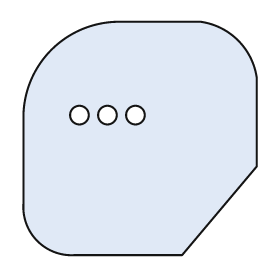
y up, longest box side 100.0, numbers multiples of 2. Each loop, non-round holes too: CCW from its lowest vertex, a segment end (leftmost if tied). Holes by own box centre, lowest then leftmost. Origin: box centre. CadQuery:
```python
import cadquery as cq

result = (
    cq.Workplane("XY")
    .moveTo(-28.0, -50.0)
    .lineTo(18.0, -50.0)
    .lineTo(50.0, -12.0)
    .lineTo(50.0, 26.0)
    .threePointArc((42.0, 42.0), (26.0, 50.0))
    .lineTo(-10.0, 50.0)
    .threePointArc((-38.0, 38.0), (-50.0, 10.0))
    .lineTo(-50.0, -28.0)
    .threePointArc((-44.0, -44.0), (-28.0, -50.0))
    .close()
    .moveTo(-26.0, 10.0)
    .circle(4.0)
    .moveTo(-14.0, 10.0)
    .circle(4.0)
    .moveTo(-2.0, 10.0)
    .circle(4.0)
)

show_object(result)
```